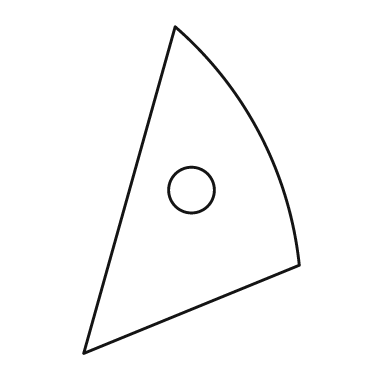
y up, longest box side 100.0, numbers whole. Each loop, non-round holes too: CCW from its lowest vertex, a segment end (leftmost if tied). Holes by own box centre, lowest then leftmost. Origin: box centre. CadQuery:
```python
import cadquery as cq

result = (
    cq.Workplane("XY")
    .moveTo(-33.0, -50.0)
    .lineTo(33.0, -23.0)
    .threePointArc((21.0, 17.0), (-5.0, 50.0))
    .close()
    .moveTo(0.0, 0.0)
    .circle(7.0)
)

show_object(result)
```